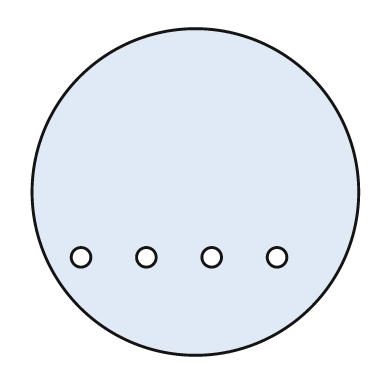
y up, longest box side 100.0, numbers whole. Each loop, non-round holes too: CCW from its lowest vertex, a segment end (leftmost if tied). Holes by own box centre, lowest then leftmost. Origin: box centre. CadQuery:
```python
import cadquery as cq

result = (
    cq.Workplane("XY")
    .moveTo(0.0, 0.0)
    .circle(50.0)
    .moveTo(-35.0, -20.0)
    .circle(3.0)
    .moveTo(-15.0, -20.0)
    .circle(3.0)
    .moveTo(5.0, -20.0)
    .circle(3.0)
    .moveTo(25.0, -20.0)
    .circle(3.0)
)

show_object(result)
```